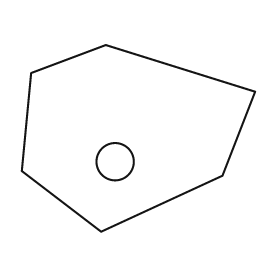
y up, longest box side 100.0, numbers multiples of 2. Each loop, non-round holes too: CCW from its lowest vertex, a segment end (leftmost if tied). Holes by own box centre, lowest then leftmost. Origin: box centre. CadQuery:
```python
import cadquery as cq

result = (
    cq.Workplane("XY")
    .moveTo(-16.0, -40.0)
    .lineTo(36.0, -16.0)
    .lineTo(50.0, 20.0)
    .lineTo(-14.0, 40.0)
    .lineTo(-46.0, 28.0)
    .lineTo(-50.0, -14.0)
    .close()
    .moveTo(-10.0, -10.0)
    .circle(8.0)
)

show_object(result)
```